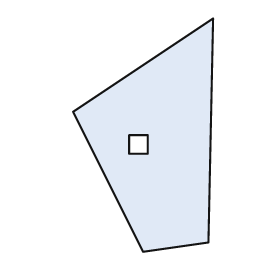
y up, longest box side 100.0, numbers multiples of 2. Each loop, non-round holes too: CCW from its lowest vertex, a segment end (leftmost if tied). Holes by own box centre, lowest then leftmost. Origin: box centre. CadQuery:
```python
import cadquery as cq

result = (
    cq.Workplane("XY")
    .moveTo(0.0, -50.0)
    .lineTo(28.0, -46.0)
    .lineTo(30.0, 50.0)
    .lineTo(-30.0, 10.0)
    .close()
    .moveTo(-6.0, -8.0)
    .lineTo(2.0, -8.0)
    .lineTo(2.0, 0.0)
    .lineTo(-6.0, 0.0)
    .close()
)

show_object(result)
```